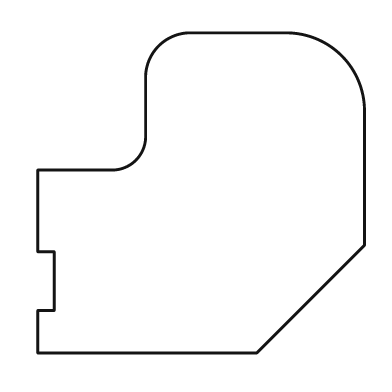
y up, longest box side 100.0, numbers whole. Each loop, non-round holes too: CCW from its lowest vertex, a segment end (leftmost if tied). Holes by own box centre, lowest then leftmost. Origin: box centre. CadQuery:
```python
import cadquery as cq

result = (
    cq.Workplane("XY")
    .moveTo(-50.0, -49.0)
    .lineTo(17.0, -49.0)
    .lineTo(50.0, -16.0)
    .lineTo(50.0, 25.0)
    .threePointArc((43.0, 42.0), (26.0, 49.0))
    .lineTo(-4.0, 49.0)
    .threePointArc((-13.0, 45.0), (-17.0, 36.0))
    .lineTo(-17.0, 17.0)
    .threePointArc((-20.0, 10.0), (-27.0, 7.0))
    .lineTo(-50.0, 7.0)
    .lineTo(-50.0, -18.0)
    .lineTo(-45.0, -18.0)
    .lineTo(-45.0, -36.0)
    .lineTo(-50.0, -36.0)
    .close()
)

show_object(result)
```